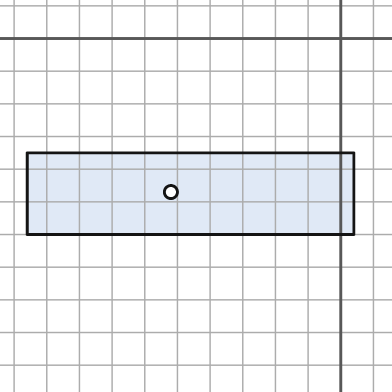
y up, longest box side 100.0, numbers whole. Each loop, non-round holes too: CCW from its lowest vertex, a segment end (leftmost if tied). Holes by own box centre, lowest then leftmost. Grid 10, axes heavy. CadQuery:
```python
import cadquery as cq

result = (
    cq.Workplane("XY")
    .moveTo(-96.0, -60.0)
    .lineTo(4.0, -60.0)
    .lineTo(4.0, -35.0)
    .lineTo(-96.0, -35.0)
    .close()
    .moveTo(-52.0, -47.0)
    .circle(2.0)
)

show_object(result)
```